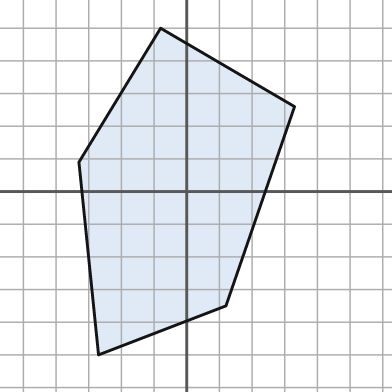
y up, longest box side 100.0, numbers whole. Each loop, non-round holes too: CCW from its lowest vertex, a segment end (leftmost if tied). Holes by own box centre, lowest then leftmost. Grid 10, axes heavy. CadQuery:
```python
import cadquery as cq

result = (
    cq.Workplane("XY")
    .moveTo(-27.0, -50.0)
    .lineTo(12.0, -35.0)
    .lineTo(33.0, 26.0)
    .lineTo(-8.0, 50.0)
    .lineTo(-33.0, 9.0)
    .close()
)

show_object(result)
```